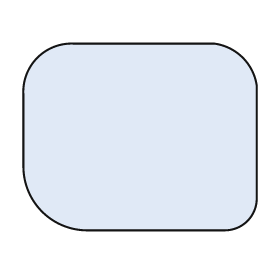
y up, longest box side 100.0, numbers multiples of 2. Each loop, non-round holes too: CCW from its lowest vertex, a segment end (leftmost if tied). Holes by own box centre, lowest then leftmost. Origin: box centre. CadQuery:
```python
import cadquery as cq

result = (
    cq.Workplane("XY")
    .moveTo(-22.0, -40.0)
    .lineTo(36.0, -40.0)
    .threePointArc((46.0, -36.0), (50.0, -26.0))
    .lineTo(50.0, 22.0)
    .threePointArc((44.0, 34.0), (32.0, 40.0))
    .lineTo(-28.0, 40.0)
    .threePointArc((-44.0, 34.0), (-50.0, 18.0))
    .lineTo(-50.0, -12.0)
    .threePointArc((-42.0, -32.0), (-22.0, -40.0))
    .close()
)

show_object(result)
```